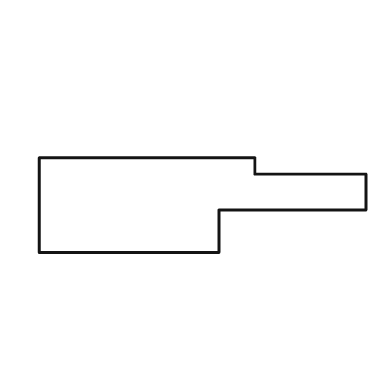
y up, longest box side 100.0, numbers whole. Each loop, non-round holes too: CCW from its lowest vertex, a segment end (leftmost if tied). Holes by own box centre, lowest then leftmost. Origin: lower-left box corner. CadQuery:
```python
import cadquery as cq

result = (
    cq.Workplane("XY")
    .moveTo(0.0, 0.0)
    .lineTo(55.0, 0.0)
    .lineTo(55.0, 13.0)
    .lineTo(100.0, 13.0)
    .lineTo(100.0, 24.0)
    .lineTo(66.0, 24.0)
    .lineTo(66.0, 29.0)
    .lineTo(0.0, 29.0)
    .close()
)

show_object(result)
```